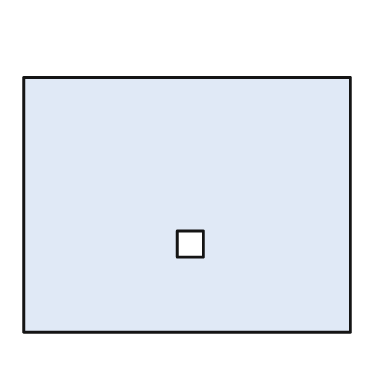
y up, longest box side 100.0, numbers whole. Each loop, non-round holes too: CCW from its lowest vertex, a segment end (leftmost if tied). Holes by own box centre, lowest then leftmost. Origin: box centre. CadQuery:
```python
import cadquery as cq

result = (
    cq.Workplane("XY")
    .moveTo(-50.0, -39.0)
    .lineTo(50.0, -39.0)
    .lineTo(50.0, 39.0)
    .lineTo(-50.0, 39.0)
    .close()
    .moveTo(-3.0, -16.0)
    .lineTo(5.0, -16.0)
    .lineTo(5.0, -8.0)
    .lineTo(-3.0, -8.0)
    .close()
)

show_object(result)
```